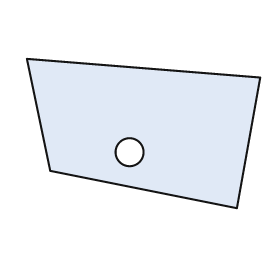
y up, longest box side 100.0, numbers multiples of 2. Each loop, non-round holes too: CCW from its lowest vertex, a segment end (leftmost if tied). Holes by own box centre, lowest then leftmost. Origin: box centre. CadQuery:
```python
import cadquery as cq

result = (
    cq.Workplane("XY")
    .moveTo(40.0, -32.0)
    .lineTo(50.0, 24.0)
    .lineTo(-50.0, 32.0)
    .lineTo(-40.0, -16.0)
    .close()
    .moveTo(-6.0, -8.0)
    .circle(6.0)
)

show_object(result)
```